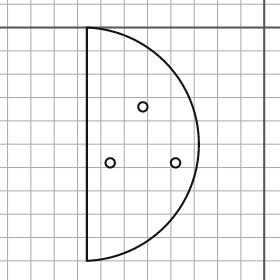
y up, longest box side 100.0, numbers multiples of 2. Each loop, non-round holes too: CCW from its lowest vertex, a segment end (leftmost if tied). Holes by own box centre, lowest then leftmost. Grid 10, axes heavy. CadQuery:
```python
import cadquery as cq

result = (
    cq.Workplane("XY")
    .moveTo(-76.0, -100.0)
    .threePointArc((-28.0, -50.0), (-76.0, 0.0))
    .close()
    .moveTo(-66.0, -58.0)
    .circle(2.0)
    .moveTo(-38.0, -58.0)
    .circle(2.0)
    .moveTo(-52.0, -34.0)
    .circle(2.0)
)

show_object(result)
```